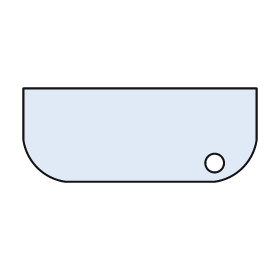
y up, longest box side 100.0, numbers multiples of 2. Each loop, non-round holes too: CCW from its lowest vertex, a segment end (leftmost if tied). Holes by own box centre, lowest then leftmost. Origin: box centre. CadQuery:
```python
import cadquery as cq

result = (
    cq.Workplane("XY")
    .moveTo(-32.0, -20.0)
    .lineTo(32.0, -20.0)
    .threePointArc((44.0, -14.0), (50.0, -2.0))
    .lineTo(50.0, 20.0)
    .lineTo(-50.0, 20.0)
    .lineTo(-50.0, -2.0)
    .threePointArc((-44.0, -14.0), (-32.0, -20.0))
    .close()
    .moveTo(32.0, -12.0)
    .circle(4.0)
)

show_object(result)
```